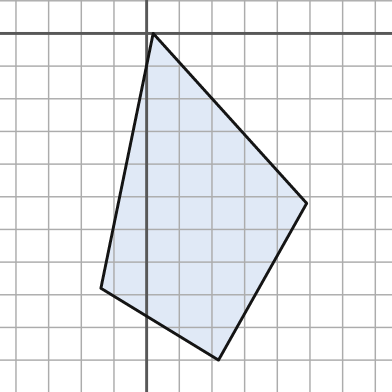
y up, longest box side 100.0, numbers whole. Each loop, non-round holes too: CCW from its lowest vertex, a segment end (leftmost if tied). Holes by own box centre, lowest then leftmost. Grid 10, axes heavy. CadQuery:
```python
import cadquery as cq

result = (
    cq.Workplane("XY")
    .moveTo(22.0, -100.0)
    .lineTo(49.0, -52.0)
    .lineTo(2.0, 0.0)
    .lineTo(-14.0, -78.0)
    .close()
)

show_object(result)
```